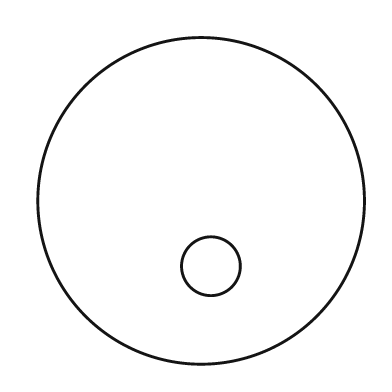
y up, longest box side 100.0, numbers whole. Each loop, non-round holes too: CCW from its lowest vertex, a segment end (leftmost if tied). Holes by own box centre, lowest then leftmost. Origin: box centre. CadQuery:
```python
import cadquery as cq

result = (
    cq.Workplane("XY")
    .moveTo(0.0, 0.0)
    .circle(50.0)
    .moveTo(3.0, -20.0)
    .circle(9.0)
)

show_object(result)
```